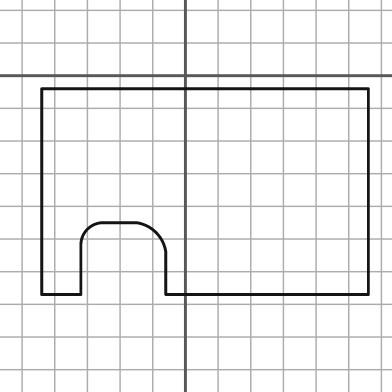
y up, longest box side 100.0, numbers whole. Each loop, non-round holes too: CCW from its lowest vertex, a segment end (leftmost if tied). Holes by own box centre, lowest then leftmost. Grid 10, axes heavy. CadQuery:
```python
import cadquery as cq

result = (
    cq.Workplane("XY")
    .moveTo(-44.0, -67.0)
    .lineTo(-32.0, -67.0)
    .lineTo(-32.0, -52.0)
    .threePointArc((-30.0, -47.0), (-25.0, -45.0))
    .lineTo(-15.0, -45.0)
    .threePointArc((-9.0, -48.0), (-6.0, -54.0))
    .lineTo(-6.0, -67.0)
    .lineTo(56.0, -67.0)
    .lineTo(56.0, -4.0)
    .lineTo(-44.0, -4.0)
    .close()
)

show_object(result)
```